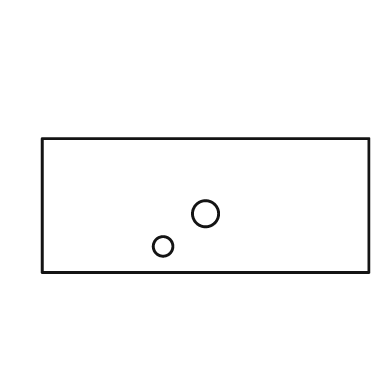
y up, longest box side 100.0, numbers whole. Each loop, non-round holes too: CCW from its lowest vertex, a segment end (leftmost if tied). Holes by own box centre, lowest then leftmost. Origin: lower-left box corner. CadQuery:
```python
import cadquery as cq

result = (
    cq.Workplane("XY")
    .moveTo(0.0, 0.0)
    .lineTo(100.0, 0.0)
    .lineTo(100.0, 41.0)
    .lineTo(0.0, 41.0)
    .close()
    .moveTo(37.0, 8.0)
    .circle(3.0)
    .moveTo(50.0, 18.0)
    .circle(4.0)
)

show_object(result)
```